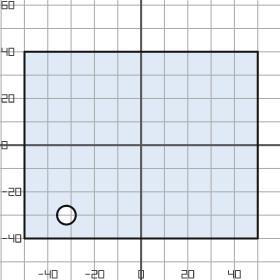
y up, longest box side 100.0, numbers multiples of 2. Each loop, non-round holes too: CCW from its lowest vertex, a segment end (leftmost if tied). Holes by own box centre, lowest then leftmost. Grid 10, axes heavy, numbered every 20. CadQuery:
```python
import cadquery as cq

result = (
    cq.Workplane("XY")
    .moveTo(-50.0, -40.0)
    .lineTo(50.0, -40.0)
    .lineTo(50.0, 40.0)
    .lineTo(-50.0, 40.0)
    .close()
    .moveTo(-32.0, -30.0)
    .circle(4.0)
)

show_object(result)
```